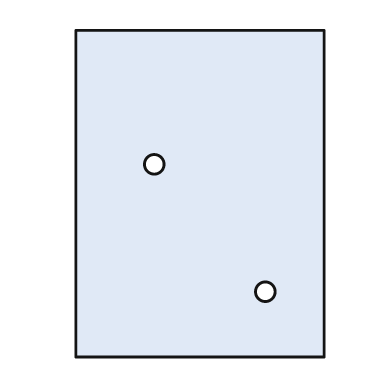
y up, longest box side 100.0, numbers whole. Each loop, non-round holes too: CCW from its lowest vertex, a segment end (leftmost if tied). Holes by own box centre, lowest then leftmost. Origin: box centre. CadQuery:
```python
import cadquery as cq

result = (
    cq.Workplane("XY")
    .moveTo(-38.0, -50.0)
    .lineTo(38.0, -50.0)
    .lineTo(38.0, 50.0)
    .lineTo(-38.0, 50.0)
    .close()
    .moveTo(20.0, -30.0)
    .circle(3.0)
    .moveTo(-14.0, 9.0)
    .circle(3.0)
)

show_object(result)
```